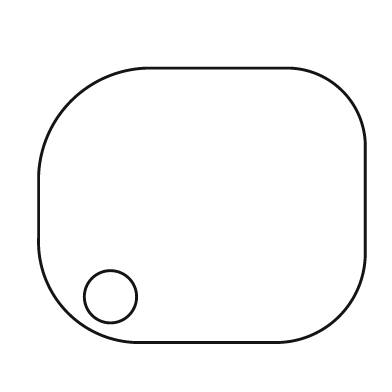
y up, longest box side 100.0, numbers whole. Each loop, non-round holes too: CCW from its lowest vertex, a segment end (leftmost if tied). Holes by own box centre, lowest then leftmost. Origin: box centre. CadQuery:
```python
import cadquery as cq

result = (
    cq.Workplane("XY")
    .moveTo(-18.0, -42.0)
    .lineTo(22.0, -42.0)
    .threePointArc((42.0, -34.0), (50.0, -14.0))
    .lineTo(50.0, 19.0)
    .threePointArc((43.0, 35.0), (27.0, 42.0))
    .lineTo(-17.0, 42.0)
    .threePointArc((-40.0, 32.0), (-50.0, 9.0))
    .lineTo(-50.0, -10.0)
    .threePointArc((-41.0, -33.0), (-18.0, -42.0))
    .close()
    .moveTo(-28.0, -28.0)
    .circle(8.0)
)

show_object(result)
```